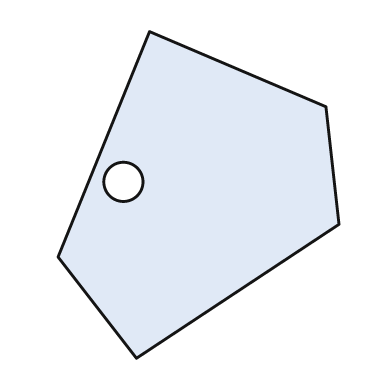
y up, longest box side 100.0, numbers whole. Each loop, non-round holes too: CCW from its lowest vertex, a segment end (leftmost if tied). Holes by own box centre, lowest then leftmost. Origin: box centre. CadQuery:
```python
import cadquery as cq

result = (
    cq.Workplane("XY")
    .moveTo(-19.0, -50.0)
    .lineTo(43.0, -9.0)
    .lineTo(39.0, 27.0)
    .lineTo(-15.0, 50.0)
    .lineTo(-43.0, -19.0)
    .close()
    .moveTo(-23.0, 4.0)
    .circle(6.0)
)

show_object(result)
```